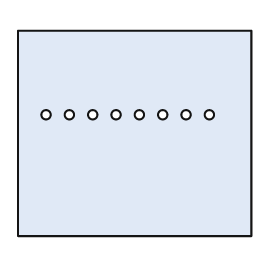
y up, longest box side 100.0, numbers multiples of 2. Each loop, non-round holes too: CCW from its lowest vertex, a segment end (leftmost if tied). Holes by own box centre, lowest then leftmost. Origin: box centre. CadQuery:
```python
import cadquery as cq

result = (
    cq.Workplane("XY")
    .moveTo(-50.0, -44.0)
    .lineTo(50.0, -44.0)
    .lineTo(50.0, 44.0)
    .lineTo(-50.0, 44.0)
    .close()
    .moveTo(-38.0, 8.0)
    .circle(2.0)
    .moveTo(-28.0, 8.0)
    .circle(2.0)
    .moveTo(-18.0, 8.0)
    .circle(2.0)
    .moveTo(-8.0, 8.0)
    .circle(2.0)
    .moveTo(2.0, 8.0)
    .circle(2.0)
    .moveTo(12.0, 8.0)
    .circle(2.0)
    .moveTo(22.0, 8.0)
    .circle(2.0)
    .moveTo(32.0, 8.0)
    .circle(2.0)
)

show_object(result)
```